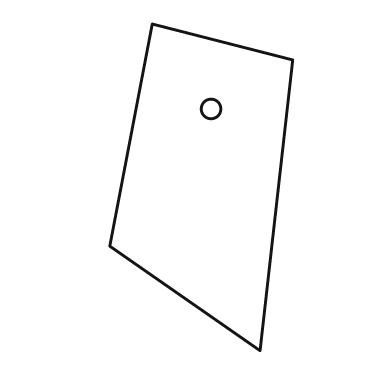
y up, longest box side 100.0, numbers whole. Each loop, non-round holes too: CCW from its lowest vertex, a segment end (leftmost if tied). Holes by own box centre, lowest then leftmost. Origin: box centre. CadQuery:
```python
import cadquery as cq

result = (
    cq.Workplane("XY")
    .moveTo(18.0, -50.0)
    .lineTo(28.0, 39.0)
    .lineTo(-15.0, 50.0)
    .lineTo(-28.0, -18.0)
    .close()
    .moveTo(3.0, 24.0)
    .circle(3.0)
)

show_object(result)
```